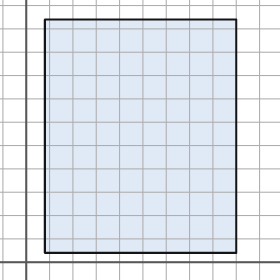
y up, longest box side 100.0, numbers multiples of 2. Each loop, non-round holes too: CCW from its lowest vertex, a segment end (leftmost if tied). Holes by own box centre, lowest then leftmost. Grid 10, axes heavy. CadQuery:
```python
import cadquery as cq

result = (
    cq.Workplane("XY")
    .moveTo(8.0, 4.0)
    .lineTo(90.0, 4.0)
    .lineTo(90.0, 104.0)
    .lineTo(8.0, 104.0)
    .close()
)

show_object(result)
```